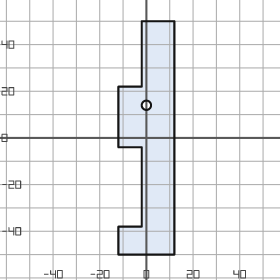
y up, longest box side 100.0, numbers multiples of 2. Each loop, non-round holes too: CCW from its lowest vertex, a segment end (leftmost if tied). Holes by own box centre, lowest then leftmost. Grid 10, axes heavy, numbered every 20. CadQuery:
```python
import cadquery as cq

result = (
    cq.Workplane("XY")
    .moveTo(-12.0, -50.0)
    .lineTo(12.0, -50.0)
    .lineTo(12.0, 50.0)
    .lineTo(-2.0, 50.0)
    .lineTo(-2.0, 22.0)
    .lineTo(-12.0, 22.0)
    .lineTo(-12.0, -4.0)
    .lineTo(-2.0, -4.0)
    .lineTo(-2.0, -38.0)
    .lineTo(-12.0, -38.0)
    .close()
    .moveTo(0.0, 14.0)
    .circle(2.0)
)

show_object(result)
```